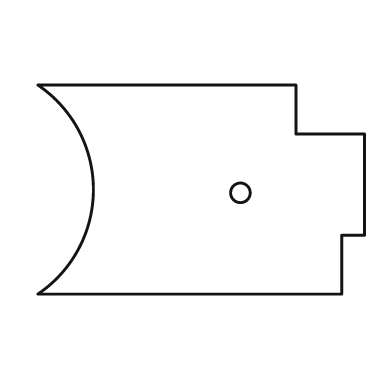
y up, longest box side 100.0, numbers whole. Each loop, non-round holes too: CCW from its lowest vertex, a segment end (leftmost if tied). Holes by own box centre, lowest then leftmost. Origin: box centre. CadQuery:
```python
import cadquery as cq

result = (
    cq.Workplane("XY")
    .moveTo(-50.0, -32.0)
    .lineTo(43.0, -32.0)
    .lineTo(43.0, -14.0)
    .lineTo(50.0, -14.0)
    .lineTo(50.0, 17.0)
    .lineTo(29.0, 17.0)
    .lineTo(29.0, 32.0)
    .lineTo(-50.0, 32.0)
    .threePointArc((-33.0, 0.0), (-50.0, -32.0))
    .close()
    .moveTo(12.0, -1.0)
    .circle(3.0)
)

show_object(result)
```